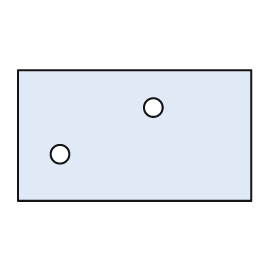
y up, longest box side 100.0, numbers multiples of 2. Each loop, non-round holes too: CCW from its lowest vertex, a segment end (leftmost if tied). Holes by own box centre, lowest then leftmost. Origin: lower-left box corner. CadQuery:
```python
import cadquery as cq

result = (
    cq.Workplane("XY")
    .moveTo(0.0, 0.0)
    .lineTo(100.0, 0.0)
    .lineTo(100.0, 56.0)
    .lineTo(0.0, 56.0)
    .close()
    .moveTo(18.0, 20.0)
    .circle(4.0)
    .moveTo(58.0, 40.0)
    .circle(4.0)
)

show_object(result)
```